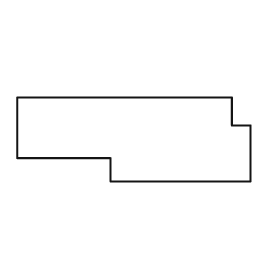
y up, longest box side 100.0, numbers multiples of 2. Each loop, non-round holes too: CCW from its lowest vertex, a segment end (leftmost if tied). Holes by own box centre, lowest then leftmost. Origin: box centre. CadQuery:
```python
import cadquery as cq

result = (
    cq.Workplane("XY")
    .moveTo(-10.0, -18.0)
    .lineTo(50.0, -18.0)
    .lineTo(50.0, 6.0)
    .lineTo(42.0, 6.0)
    .lineTo(42.0, 18.0)
    .lineTo(-50.0, 18.0)
    .lineTo(-50.0, -8.0)
    .lineTo(-10.0, -8.0)
    .close()
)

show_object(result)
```